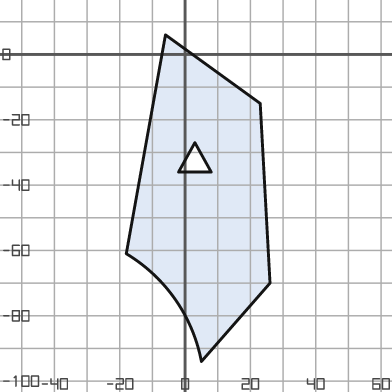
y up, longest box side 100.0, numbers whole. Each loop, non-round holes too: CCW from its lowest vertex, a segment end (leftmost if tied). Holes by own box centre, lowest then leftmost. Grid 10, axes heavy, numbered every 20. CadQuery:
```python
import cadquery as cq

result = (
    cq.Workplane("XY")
    .moveTo(5.0, -94.0)
    .lineTo(26.0, -70.0)
    .lineTo(23.0, -15.0)
    .lineTo(-6.0, 6.0)
    .lineTo(-18.0, -61.0)
    .threePointArc((-3.0, -75.0), (5.0, -94.0))
    .close()
    .moveTo(-2.0, -36.0)
    .lineTo(8.0, -36.0)
    .lineTo(3.0, -27.0)
    .close()
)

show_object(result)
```